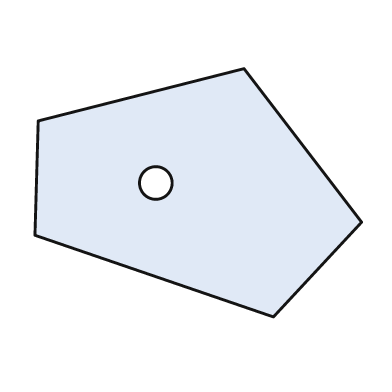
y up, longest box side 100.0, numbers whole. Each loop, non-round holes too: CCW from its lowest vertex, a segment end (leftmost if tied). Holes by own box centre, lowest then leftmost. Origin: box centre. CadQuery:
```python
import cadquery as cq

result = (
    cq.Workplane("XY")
    .moveTo(23.0, -38.0)
    .lineTo(50.0, -9.0)
    .lineTo(14.0, 38.0)
    .lineTo(-49.0, 22.0)
    .lineTo(-50.0, -13.0)
    .close()
    .moveTo(-13.0, 3.0)
    .circle(5.0)
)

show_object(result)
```